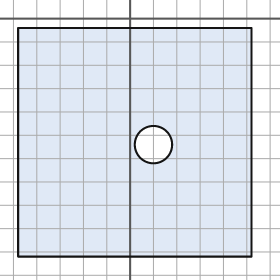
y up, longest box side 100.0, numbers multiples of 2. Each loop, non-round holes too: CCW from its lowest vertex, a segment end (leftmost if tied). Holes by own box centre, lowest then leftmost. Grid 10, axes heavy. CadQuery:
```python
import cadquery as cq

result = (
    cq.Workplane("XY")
    .moveTo(-48.0, -102.0)
    .lineTo(52.0, -102.0)
    .lineTo(52.0, -4.0)
    .lineTo(-48.0, -4.0)
    .close()
    .moveTo(10.0, -54.0)
    .circle(8.0)
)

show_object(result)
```